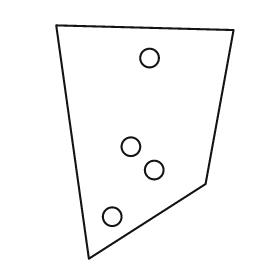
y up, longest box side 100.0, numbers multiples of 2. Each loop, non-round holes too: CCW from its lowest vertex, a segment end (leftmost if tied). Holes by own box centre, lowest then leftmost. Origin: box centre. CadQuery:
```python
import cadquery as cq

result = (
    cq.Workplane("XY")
    .moveTo(-24.0, -50.0)
    .lineTo(26.0, -18.0)
    .lineTo(38.0, 48.0)
    .lineTo(-38.0, 50.0)
    .close()
    .moveTo(-14.0, -32.0)
    .circle(4.0)
    .moveTo(4.0, -12.0)
    .circle(4.0)
    .moveTo(-6.0, -2.0)
    .circle(4.0)
    .moveTo(2.0, 36.0)
    .circle(4.0)
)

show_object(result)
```